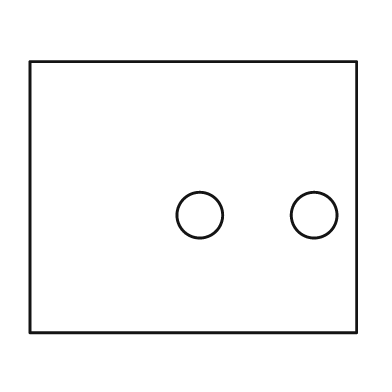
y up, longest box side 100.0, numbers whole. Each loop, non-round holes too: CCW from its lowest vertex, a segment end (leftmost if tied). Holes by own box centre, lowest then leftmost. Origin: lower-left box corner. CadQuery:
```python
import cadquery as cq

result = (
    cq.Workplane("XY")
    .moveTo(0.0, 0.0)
    .lineTo(100.0, 0.0)
    .lineTo(100.0, 83.0)
    .lineTo(0.0, 83.0)
    .close()
    .moveTo(52.0, 36.0)
    .circle(7.0)
    .moveTo(87.0, 36.0)
    .circle(7.0)
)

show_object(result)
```